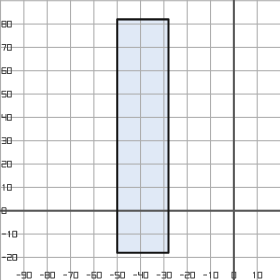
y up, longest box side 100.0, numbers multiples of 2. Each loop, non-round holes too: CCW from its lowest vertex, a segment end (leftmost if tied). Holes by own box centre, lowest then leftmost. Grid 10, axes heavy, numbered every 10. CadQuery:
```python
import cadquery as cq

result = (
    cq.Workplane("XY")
    .moveTo(-50.0, -18.0)
    .lineTo(-28.0, -18.0)
    .lineTo(-28.0, 82.0)
    .lineTo(-50.0, 82.0)
    .close()
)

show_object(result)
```